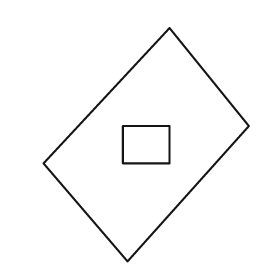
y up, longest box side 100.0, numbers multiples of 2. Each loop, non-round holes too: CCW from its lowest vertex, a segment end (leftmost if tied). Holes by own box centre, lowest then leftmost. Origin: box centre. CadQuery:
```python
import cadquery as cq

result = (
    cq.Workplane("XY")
    .moveTo(-8.0, -50.0)
    .lineTo(44.0, 8.0)
    .lineTo(10.0, 50.0)
    .lineTo(-44.0, -8.0)
    .close()
    .moveTo(-10.0, -8.0)
    .lineTo(10.0, -8.0)
    .lineTo(10.0, 8.0)
    .lineTo(-10.0, 8.0)
    .close()
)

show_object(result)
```